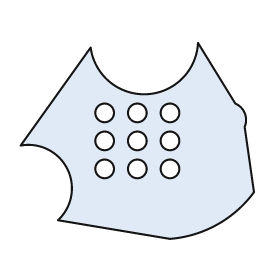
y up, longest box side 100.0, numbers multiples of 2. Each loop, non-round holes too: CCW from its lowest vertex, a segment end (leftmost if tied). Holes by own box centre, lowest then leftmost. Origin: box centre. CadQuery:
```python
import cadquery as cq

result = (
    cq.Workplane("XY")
    .moveTo(14.0, -42.0)
    .threePointArc((34.0, -36.0), (50.0, -22.0))
    .lineTo(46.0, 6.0)
    .threePointArc((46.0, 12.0), (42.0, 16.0))
    .lineTo(26.0, 42.0)
    .threePointArc((4.0, 20.0), (-20.0, 40.0))
    .lineTo(-50.0, -2.0)
    .threePointArc((-30.0, -12.0), (-34.0, -34.0))
    .close()
    .moveTo(-14.0, -12.0)
    .circle(4.0)
    .moveTo(0.0, -12.0)
    .circle(4.0)
    .moveTo(14.0, -12.0)
    .circle(4.0)
    .moveTo(-14.0, 0.0)
    .circle(4.0)
    .moveTo(0.0, 0.0)
    .circle(4.0)
    .moveTo(14.0, 0.0)
    .circle(4.0)
    .moveTo(-14.0, 12.0)
    .circle(4.0)
    .moveTo(0.0, 12.0)
    .circle(4.0)
    .moveTo(14.0, 12.0)
    .circle(4.0)
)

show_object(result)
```